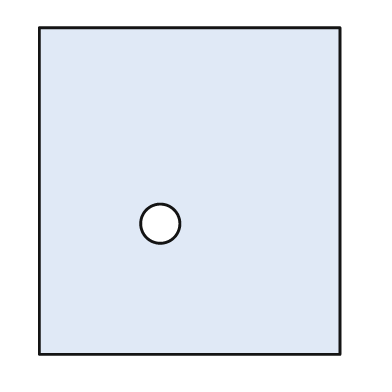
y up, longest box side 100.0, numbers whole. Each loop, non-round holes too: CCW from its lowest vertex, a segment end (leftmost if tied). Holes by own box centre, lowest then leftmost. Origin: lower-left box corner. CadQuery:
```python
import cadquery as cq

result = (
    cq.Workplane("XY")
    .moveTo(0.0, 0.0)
    .lineTo(92.0, 0.0)
    .lineTo(92.0, 100.0)
    .lineTo(0.0, 100.0)
    .close()
    .moveTo(37.0, 40.0)
    .circle(6.0)
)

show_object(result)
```